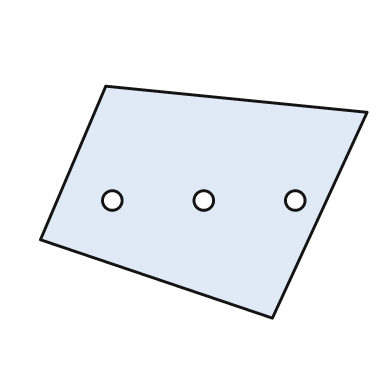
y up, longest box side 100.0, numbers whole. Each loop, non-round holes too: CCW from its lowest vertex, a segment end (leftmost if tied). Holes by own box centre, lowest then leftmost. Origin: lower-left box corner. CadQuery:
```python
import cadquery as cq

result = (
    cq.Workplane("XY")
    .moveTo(71.0, 0.0)
    .lineTo(100.0, 63.0)
    .lineTo(20.0, 71.0)
    .lineTo(0.0, 24.0)
    .close()
    .moveTo(22.0, 36.0)
    .circle(3.0)
    .moveTo(50.0, 36.0)
    .circle(3.0)
    .moveTo(78.0, 36.0)
    .circle(3.0)
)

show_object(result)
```